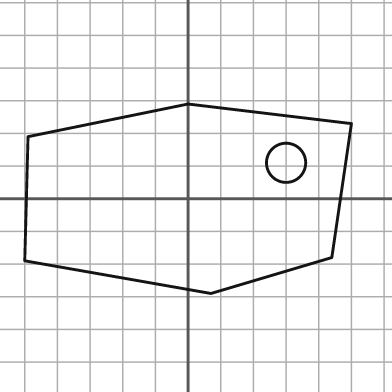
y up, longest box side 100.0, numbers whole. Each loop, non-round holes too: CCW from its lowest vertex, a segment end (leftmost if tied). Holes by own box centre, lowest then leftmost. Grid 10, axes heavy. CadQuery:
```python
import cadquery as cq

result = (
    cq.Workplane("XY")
    .moveTo(7.0, -29.0)
    .lineTo(44.0, -18.0)
    .lineTo(50.0, 23.0)
    .lineTo(0.0, 29.0)
    .lineTo(-49.0, 19.0)
    .lineTo(-50.0, -19.0)
    .close()
    .moveTo(30.0, 11.0)
    .circle(6.0)
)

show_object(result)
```